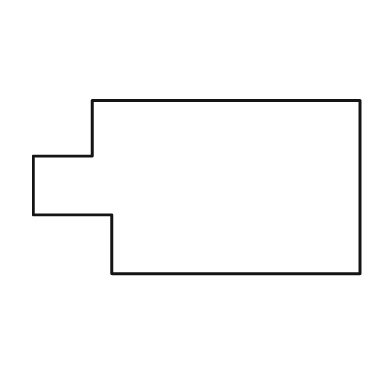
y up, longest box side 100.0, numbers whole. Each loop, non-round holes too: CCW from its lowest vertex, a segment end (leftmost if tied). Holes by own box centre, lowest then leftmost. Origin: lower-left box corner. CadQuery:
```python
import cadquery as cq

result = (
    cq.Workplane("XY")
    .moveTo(24.0, 0.0)
    .lineTo(100.0, 0.0)
    .lineTo(100.0, 53.0)
    .lineTo(18.0, 53.0)
    .lineTo(18.0, 36.0)
    .lineTo(0.0, 36.0)
    .lineTo(0.0, 18.0)
    .lineTo(24.0, 18.0)
    .close()
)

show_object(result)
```